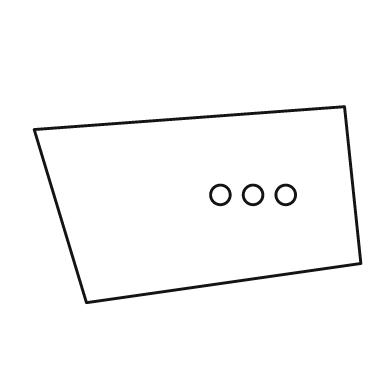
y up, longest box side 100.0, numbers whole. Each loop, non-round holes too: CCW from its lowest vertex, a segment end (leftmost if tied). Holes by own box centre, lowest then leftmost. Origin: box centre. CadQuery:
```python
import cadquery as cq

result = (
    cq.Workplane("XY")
    .moveTo(-34.0, -30.0)
    .lineTo(50.0, -18.0)
    .lineTo(45.0, 30.0)
    .lineTo(-50.0, 23.0)
    .close()
    .moveTo(7.0, 3.0)
    .circle(3.0)
    .moveTo(17.0, 3.0)
    .circle(3.0)
    .moveTo(27.0, 3.0)
    .circle(3.0)
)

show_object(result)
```